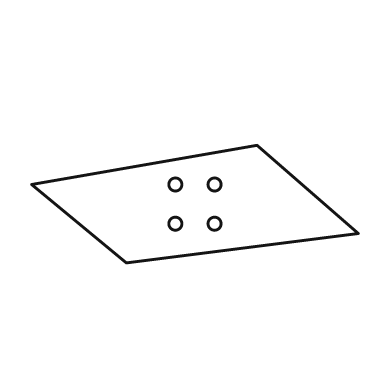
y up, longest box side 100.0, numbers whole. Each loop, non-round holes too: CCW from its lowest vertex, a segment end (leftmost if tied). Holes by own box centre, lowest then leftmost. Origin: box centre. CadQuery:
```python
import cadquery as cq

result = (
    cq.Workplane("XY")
    .moveTo(-21.0, -18.0)
    .lineTo(50.0, -9.0)
    .lineTo(19.0, 18.0)
    .lineTo(-50.0, 6.0)
    .close()
    .moveTo(-6.0, -6.0)
    .circle(2.0)
    .moveTo(6.0, -6.0)
    .circle(2.0)
    .moveTo(-6.0, 6.0)
    .circle(2.0)
    .moveTo(6.0, 6.0)
    .circle(2.0)
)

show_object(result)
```